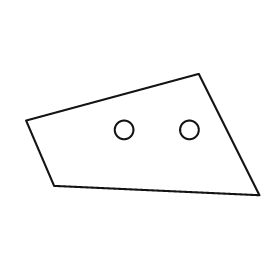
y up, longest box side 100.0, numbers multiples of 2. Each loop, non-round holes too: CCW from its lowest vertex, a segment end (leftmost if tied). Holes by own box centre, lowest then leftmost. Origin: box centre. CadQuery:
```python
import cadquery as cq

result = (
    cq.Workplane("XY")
    .moveTo(50.0, -26.0)
    .lineTo(24.0, 26.0)
    .lineTo(-50.0, 6.0)
    .lineTo(-38.0, -22.0)
    .close()
    .moveTo(-8.0, 2.0)
    .circle(4.0)
    .moveTo(20.0, 2.0)
    .circle(4.0)
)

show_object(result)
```